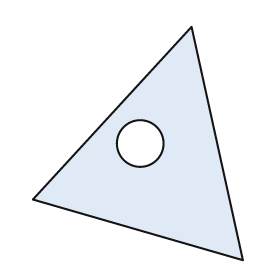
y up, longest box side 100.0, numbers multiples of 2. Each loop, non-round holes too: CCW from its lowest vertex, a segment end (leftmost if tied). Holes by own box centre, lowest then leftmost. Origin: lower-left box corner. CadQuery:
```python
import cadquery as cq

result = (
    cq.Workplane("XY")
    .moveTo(90.0, 0.0)
    .lineTo(68.0, 100.0)
    .lineTo(0.0, 26.0)
    .close()
    .moveTo(46.0, 50.0)
    .circle(10.0)
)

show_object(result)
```